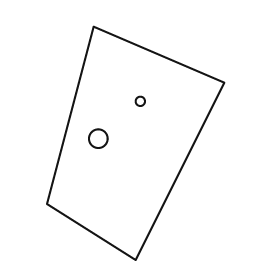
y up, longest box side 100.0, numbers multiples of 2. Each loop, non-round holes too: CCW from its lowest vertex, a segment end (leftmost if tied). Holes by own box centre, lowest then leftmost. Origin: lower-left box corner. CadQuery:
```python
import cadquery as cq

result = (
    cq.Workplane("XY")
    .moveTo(38.0, 0.0)
    .lineTo(76.0, 76.0)
    .lineTo(20.0, 100.0)
    .lineTo(0.0, 24.0)
    .close()
    .moveTo(22.0, 52.0)
    .circle(4.0)
    .moveTo(40.0, 68.0)
    .circle(2.0)
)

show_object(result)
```